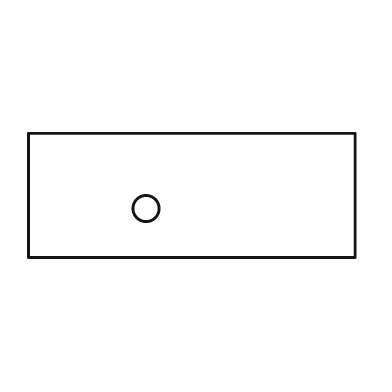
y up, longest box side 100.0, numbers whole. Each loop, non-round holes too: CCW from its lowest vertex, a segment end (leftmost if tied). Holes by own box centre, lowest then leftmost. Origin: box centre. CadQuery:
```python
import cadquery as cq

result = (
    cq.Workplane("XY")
    .moveTo(-50.0, -19.0)
    .lineTo(50.0, -19.0)
    .lineTo(50.0, 19.0)
    .lineTo(-50.0, 19.0)
    .close()
    .moveTo(-14.0, -4.0)
    .circle(4.0)
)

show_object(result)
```